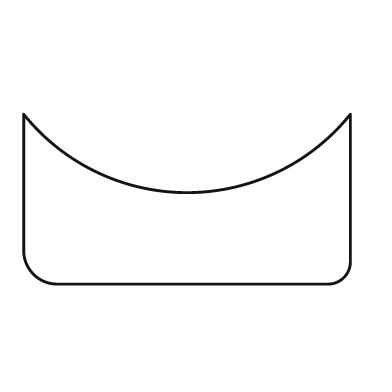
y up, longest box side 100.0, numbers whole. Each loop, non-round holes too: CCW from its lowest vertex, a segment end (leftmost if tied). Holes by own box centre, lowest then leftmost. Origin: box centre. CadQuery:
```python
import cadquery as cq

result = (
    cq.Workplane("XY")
    .moveTo(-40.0, -26.0)
    .lineTo(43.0, -26.0)
    .threePointArc((48.0, -24.0), (50.0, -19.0))
    .lineTo(50.0, 26.0)
    .threePointArc((0.0, 2.0), (-50.0, 26.0))
    .lineTo(-50.0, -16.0)
    .threePointArc((-47.0, -23.0), (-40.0, -26.0))
    .close()
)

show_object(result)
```